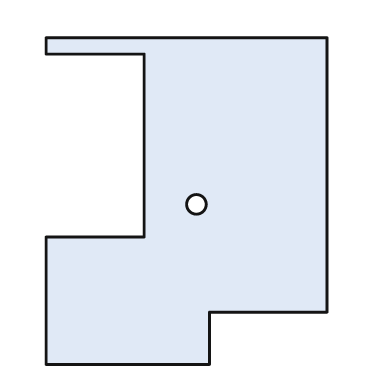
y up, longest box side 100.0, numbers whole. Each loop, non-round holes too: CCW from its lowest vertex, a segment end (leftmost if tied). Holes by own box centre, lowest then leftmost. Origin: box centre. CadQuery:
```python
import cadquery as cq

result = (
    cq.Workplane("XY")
    .moveTo(-43.0, -50.0)
    .lineTo(7.0, -50.0)
    .lineTo(7.0, -34.0)
    .lineTo(43.0, -34.0)
    .lineTo(43.0, 50.0)
    .lineTo(-43.0, 50.0)
    .lineTo(-43.0, 45.0)
    .lineTo(-13.0, 45.0)
    .lineTo(-13.0, -11.0)
    .lineTo(-43.0, -11.0)
    .close()
    .moveTo(3.0, -1.0)
    .circle(3.0)
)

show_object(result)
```